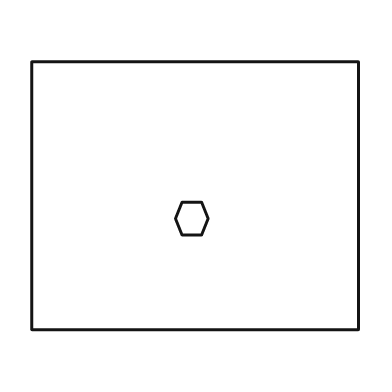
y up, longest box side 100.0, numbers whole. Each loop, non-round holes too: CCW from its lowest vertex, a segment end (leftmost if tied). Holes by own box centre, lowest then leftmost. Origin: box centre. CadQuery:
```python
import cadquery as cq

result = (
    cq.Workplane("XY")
    .moveTo(-50.0, -41.0)
    .lineTo(50.0, -41.0)
    .lineTo(50.0, 41.0)
    .lineTo(-50.0, 41.0)
    .close()
    .moveTo(-4.0, -12.0)
    .lineTo(2.0, -12.0)
    .lineTo(4.0, -7.0)
    .lineTo(2.0, -2.0)
    .lineTo(-4.0, -2.0)
    .lineTo(-6.0, -7.0)
    .close()
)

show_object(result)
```